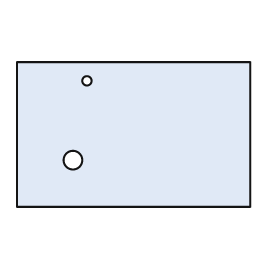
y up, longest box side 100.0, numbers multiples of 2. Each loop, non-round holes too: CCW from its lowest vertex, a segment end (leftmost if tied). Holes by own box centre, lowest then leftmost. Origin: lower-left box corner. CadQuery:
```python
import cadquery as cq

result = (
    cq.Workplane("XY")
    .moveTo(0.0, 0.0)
    .lineTo(100.0, 0.0)
    .lineTo(100.0, 62.0)
    .lineTo(0.0, 62.0)
    .close()
    .moveTo(24.0, 20.0)
    .circle(4.0)
    .moveTo(30.0, 54.0)
    .circle(2.0)
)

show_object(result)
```